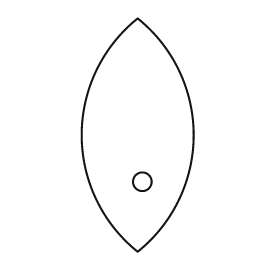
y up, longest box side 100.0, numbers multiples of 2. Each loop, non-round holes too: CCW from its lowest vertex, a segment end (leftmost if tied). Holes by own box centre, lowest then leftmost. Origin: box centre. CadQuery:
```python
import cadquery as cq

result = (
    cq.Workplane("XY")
    .moveTo(0.0, -50.0)
    .threePointArc((24.0, 0.0), (0.0, 50.0))
    .threePointArc((-24.0, 0.0), (0.0, -50.0))
    .close()
    .moveTo(2.0, -20.0)
    .circle(4.0)
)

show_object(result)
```